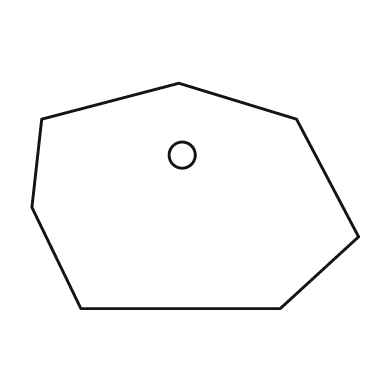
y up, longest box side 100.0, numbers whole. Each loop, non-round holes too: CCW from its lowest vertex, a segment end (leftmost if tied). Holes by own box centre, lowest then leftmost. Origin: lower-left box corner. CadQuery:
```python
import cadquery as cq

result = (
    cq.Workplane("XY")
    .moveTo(15.0, 0.0)
    .lineTo(76.0, 0.0)
    .lineTo(100.0, 22.0)
    .lineTo(81.0, 58.0)
    .lineTo(45.0, 69.0)
    .lineTo(3.0, 58.0)
    .lineTo(0.0, 31.0)
    .close()
    .moveTo(46.0, 47.0)
    .circle(4.0)
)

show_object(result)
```